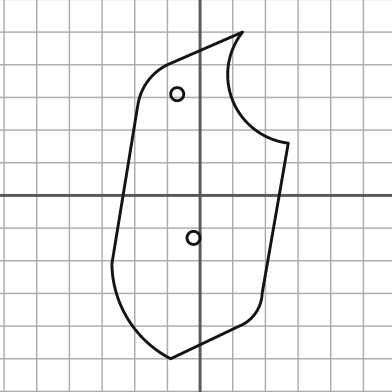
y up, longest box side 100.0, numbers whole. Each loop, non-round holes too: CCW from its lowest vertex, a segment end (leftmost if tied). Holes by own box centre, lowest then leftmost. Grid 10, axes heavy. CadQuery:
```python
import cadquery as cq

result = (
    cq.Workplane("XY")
    .moveTo(-9.0, -50.0)
    .lineTo(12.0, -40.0)
    .threePointArc((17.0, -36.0), (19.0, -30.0))
    .lineTo(27.0, 16.0)
    .threePointArc((10.0, 29.0), (13.0, 50.0))
    .lineTo(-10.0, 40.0)
    .threePointArc((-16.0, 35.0), (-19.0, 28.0))
    .lineTo(-27.0, -21.0)
    .threePointArc((-22.0, -38.0), (-9.0, -50.0))
    .close()
    .moveTo(-2.0, -13.0)
    .circle(2.0)
    .moveTo(-7.0, 31.0)
    .circle(2.0)
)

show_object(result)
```